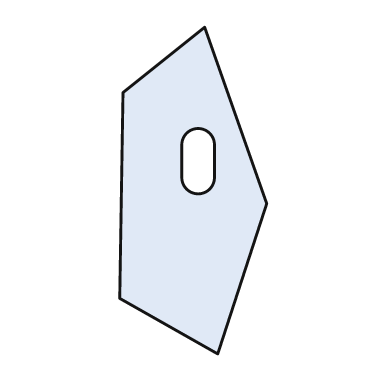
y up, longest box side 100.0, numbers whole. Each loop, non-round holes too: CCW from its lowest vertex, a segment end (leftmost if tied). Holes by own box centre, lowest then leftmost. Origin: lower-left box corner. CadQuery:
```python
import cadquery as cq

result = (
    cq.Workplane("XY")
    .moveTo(30.0, 0.0)
    .lineTo(45.0, 46.0)
    .lineTo(26.0, 100.0)
    .lineTo(1.0, 80.0)
    .lineTo(0.0, 17.0)
    .close()
    .moveTo(19.0, 54.0)
    .threePointArc((24.0, 49.0), (29.0, 54.0))
    .lineTo(29.0, 64.0)
    .threePointArc((24.0, 69.0), (19.0, 64.0))
    .close()
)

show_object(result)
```